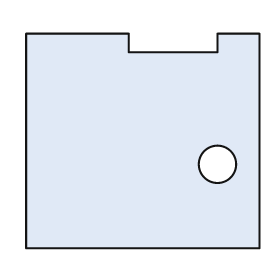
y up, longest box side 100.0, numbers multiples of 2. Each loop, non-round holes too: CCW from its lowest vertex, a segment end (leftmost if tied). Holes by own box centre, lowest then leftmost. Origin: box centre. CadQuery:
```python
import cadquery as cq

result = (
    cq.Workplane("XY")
    .moveTo(-50.0, -46.0)
    .lineTo(50.0, -46.0)
    .lineTo(50.0, 46.0)
    .lineTo(32.0, 46.0)
    .lineTo(32.0, 38.0)
    .lineTo(-6.0, 38.0)
    .lineTo(-6.0, 46.0)
    .lineTo(-50.0, 46.0)
    .close()
    .moveTo(32.0, -10.0)
    .circle(8.0)
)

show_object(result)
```